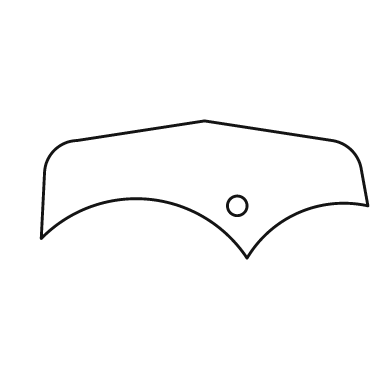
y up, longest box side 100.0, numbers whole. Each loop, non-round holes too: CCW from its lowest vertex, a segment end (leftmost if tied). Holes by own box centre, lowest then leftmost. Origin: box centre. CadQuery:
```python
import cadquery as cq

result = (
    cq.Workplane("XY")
    .moveTo(13.0, -21.0)
    .threePointArc((29.0, -7.0), (50.0, -5.0))
    .lineTo(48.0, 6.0)
    .threePointArc((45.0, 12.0), (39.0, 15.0))
    .lineTo(0.0, 21.0)
    .lineTo(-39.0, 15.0)
    .threePointArc((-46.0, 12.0), (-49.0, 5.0))
    .lineTo(-50.0, -15.0)
    .threePointArc((-17.0, -3.0), (13.0, -21.0))
    .close()
    .moveTo(10.0, -5.0)
    .circle(3.0)
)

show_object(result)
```